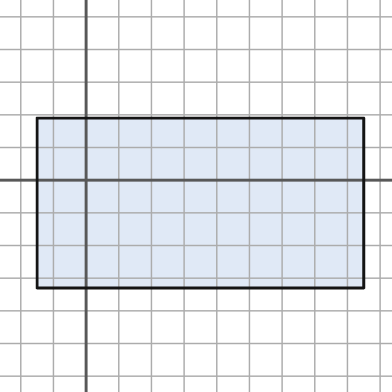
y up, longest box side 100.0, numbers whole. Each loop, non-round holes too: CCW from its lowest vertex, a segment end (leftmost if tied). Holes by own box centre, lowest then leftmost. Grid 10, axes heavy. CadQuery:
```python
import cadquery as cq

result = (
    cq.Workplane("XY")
    .moveTo(-15.0, -33.0)
    .lineTo(85.0, -33.0)
    .lineTo(85.0, 19.0)
    .lineTo(-15.0, 19.0)
    .close()
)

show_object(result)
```